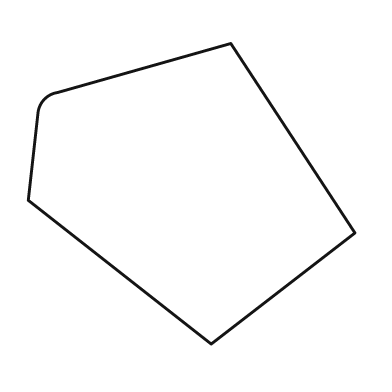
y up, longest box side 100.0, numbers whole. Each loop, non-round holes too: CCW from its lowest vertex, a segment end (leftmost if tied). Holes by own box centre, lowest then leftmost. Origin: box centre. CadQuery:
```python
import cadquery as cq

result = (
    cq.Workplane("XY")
    .moveTo(6.0, -46.0)
    .lineTo(50.0, -12.0)
    .lineTo(12.0, 46.0)
    .lineTo(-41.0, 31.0)
    .threePointArc((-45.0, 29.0), (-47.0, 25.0))
    .lineTo(-50.0, -2.0)
    .close()
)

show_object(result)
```